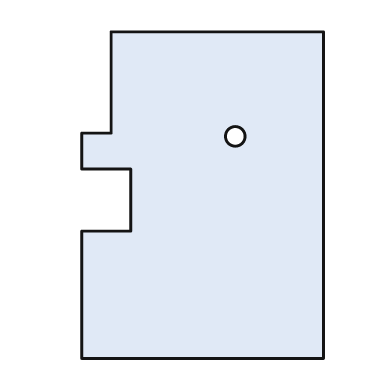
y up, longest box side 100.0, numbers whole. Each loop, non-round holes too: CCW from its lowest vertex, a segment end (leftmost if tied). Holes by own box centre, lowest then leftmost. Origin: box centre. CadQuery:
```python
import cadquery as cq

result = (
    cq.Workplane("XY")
    .moveTo(-37.0, -50.0)
    .lineTo(37.0, -50.0)
    .lineTo(37.0, 50.0)
    .lineTo(-28.0, 50.0)
    .lineTo(-28.0, 19.0)
    .lineTo(-37.0, 19.0)
    .lineTo(-37.0, 8.0)
    .lineTo(-22.0, 8.0)
    .lineTo(-22.0, -11.0)
    .lineTo(-37.0, -11.0)
    .close()
    .moveTo(10.0, 18.0)
    .circle(3.0)
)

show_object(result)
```